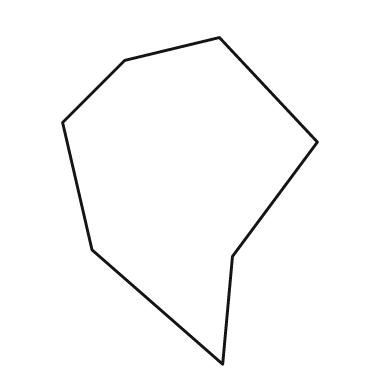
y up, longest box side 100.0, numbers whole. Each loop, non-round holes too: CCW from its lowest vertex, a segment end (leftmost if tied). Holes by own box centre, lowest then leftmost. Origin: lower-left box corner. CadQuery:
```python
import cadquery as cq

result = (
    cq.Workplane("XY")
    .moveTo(49.0, 0.0)
    .lineTo(52.0, 33.0)
    .lineTo(78.0, 68.0)
    .lineTo(48.0, 100.0)
    .lineTo(19.0, 93.0)
    .lineTo(0.0, 74.0)
    .lineTo(9.0, 35.0)
    .close()
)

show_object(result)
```